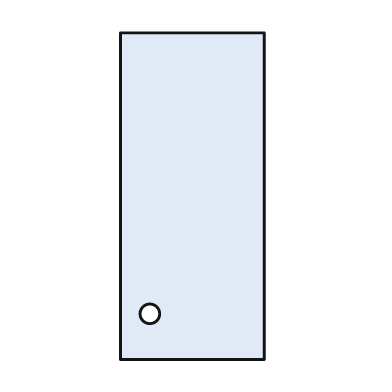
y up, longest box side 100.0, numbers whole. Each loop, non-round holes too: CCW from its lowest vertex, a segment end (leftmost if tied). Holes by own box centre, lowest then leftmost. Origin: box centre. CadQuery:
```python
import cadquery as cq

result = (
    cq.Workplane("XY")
    .moveTo(-22.0, -50.0)
    .lineTo(22.0, -50.0)
    .lineTo(22.0, 50.0)
    .lineTo(-22.0, 50.0)
    .close()
    .moveTo(-13.0, -36.0)
    .circle(3.0)
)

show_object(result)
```